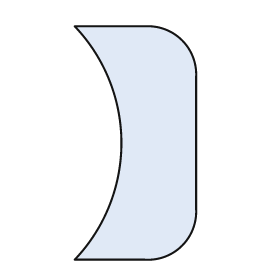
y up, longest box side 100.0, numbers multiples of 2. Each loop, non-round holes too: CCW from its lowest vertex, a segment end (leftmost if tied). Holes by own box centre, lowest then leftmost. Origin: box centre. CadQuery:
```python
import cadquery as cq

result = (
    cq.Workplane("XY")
    .moveTo(-26.0, -50.0)
    .lineTo(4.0, -50.0)
    .threePointArc((20.0, -44.0), (26.0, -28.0))
    .lineTo(26.0, 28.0)
    .threePointArc((20.0, 44.0), (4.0, 50.0))
    .lineTo(-26.0, 50.0)
    .threePointArc((-6.0, 0.0), (-26.0, -50.0))
    .close()
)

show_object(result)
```